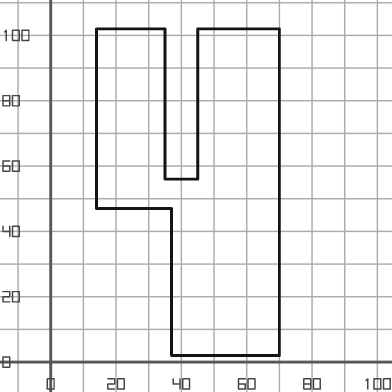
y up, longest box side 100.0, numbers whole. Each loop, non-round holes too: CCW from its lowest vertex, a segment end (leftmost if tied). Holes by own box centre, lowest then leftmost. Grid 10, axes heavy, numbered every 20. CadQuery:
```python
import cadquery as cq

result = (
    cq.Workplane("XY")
    .moveTo(37.0, 2.0)
    .lineTo(70.0, 2.0)
    .lineTo(70.0, 102.0)
    .lineTo(45.0, 102.0)
    .lineTo(45.0, 56.0)
    .lineTo(35.0, 56.0)
    .lineTo(35.0, 102.0)
    .lineTo(14.0, 102.0)
    .lineTo(14.0, 47.0)
    .lineTo(37.0, 47.0)
    .close()
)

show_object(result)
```